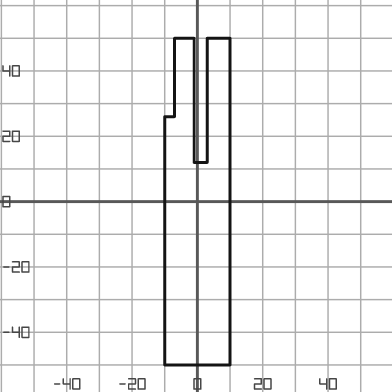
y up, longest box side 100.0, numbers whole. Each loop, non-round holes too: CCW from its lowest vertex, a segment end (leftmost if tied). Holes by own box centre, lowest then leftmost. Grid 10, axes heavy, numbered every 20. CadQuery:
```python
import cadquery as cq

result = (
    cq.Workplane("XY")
    .moveTo(-10.0, -50.0)
    .lineTo(10.0, -50.0)
    .lineTo(10.0, 50.0)
    .lineTo(3.0, 50.0)
    .lineTo(3.0, 12.0)
    .lineTo(-1.0, 12.0)
    .lineTo(-1.0, 50.0)
    .lineTo(-7.0, 50.0)
    .lineTo(-7.0, 26.0)
    .lineTo(-10.0, 26.0)
    .close()
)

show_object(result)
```